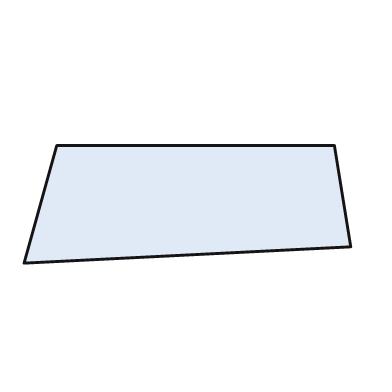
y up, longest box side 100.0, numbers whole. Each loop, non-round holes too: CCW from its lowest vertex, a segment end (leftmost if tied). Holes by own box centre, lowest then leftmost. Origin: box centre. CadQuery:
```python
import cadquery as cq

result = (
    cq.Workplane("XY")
    .moveTo(-50.0, -18.0)
    .lineTo(50.0, -13.0)
    .lineTo(45.0, 18.0)
    .lineTo(-40.0, 18.0)
    .close()
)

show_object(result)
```